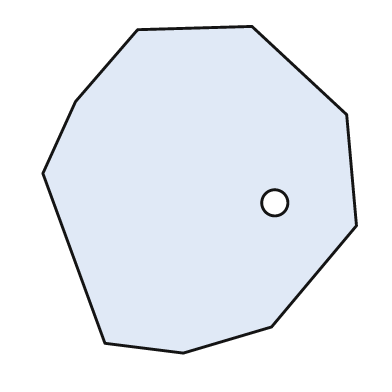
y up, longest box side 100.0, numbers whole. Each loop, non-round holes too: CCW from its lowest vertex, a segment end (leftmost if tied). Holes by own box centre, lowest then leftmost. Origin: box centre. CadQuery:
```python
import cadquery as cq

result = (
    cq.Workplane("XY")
    .moveTo(-5.0, -50.0)
    .lineTo(22.0, -42.0)
    .lineTo(48.0, -11.0)
    .lineTo(45.0, 23.0)
    .lineTo(16.0, 50.0)
    .lineTo(-19.0, 49.0)
    .lineTo(-38.0, 27.0)
    .lineTo(-48.0, 5.0)
    .lineTo(-29.0, -47.0)
    .close()
    .moveTo(23.0, -4.0)
    .circle(4.0)
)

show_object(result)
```